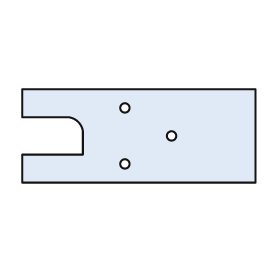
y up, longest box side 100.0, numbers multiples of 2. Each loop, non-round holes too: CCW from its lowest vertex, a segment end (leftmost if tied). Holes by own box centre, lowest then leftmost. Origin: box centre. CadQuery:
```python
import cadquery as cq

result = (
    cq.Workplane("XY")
    .moveTo(-50.0, -20.0)
    .lineTo(50.0, -20.0)
    .lineTo(50.0, 20.0)
    .lineTo(-50.0, 20.0)
    .lineTo(-50.0, 8.0)
    .lineTo(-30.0, 8.0)
    .threePointArc((-26.0, 6.0), (-24.0, 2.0))
    .lineTo(-24.0, -8.0)
    .lineTo(-50.0, -8.0)
    .close()
    .moveTo(-6.0, -12.0)
    .circle(2.0)
    .moveTo(14.0, 0.0)
    .circle(2.0)
    .moveTo(-6.0, 12.0)
    .circle(2.0)
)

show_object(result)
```